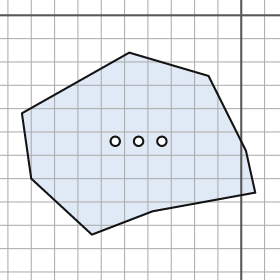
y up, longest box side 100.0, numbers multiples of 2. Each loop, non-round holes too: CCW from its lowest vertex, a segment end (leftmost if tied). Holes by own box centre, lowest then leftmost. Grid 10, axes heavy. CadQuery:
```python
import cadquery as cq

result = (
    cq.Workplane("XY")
    .moveTo(-64.0, -94.0)
    .lineTo(-38.0, -84.0)
    .lineTo(6.0, -76.0)
    .lineTo(2.0, -58.0)
    .lineTo(-14.0, -26.0)
    .lineTo(-48.0, -16.0)
    .lineTo(-94.0, -42.0)
    .lineTo(-90.0, -70.0)
    .close()
    .moveTo(-54.0, -54.0)
    .circle(2.0)
    .moveTo(-44.0, -54.0)
    .circle(2.0)
    .moveTo(-34.0, -54.0)
    .circle(2.0)
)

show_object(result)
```